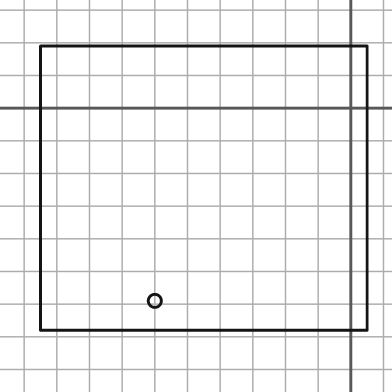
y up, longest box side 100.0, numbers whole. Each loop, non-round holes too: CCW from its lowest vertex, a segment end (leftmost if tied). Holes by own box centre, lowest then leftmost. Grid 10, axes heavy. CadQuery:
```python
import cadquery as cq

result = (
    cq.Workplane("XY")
    .moveTo(-95.0, -68.0)
    .lineTo(5.0, -68.0)
    .lineTo(5.0, 19.0)
    .lineTo(-95.0, 19.0)
    .close()
    .moveTo(-60.0, -59.0)
    .circle(2.0)
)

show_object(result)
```